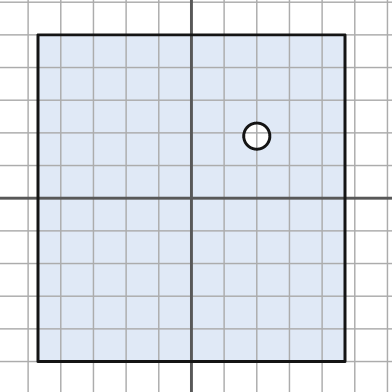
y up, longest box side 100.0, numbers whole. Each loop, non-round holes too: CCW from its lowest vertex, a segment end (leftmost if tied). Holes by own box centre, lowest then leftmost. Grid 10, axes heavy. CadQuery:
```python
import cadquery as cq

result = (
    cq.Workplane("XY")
    .moveTo(-47.0, -50.0)
    .lineTo(47.0, -50.0)
    .lineTo(47.0, 50.0)
    .lineTo(-47.0, 50.0)
    .close()
    .moveTo(20.0, 19.0)
    .circle(4.0)
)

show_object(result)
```